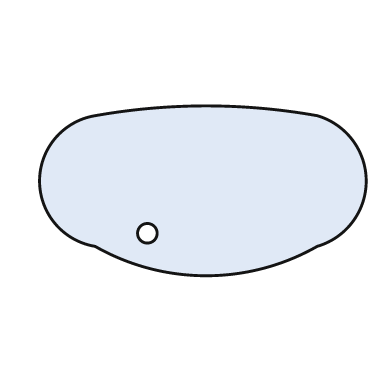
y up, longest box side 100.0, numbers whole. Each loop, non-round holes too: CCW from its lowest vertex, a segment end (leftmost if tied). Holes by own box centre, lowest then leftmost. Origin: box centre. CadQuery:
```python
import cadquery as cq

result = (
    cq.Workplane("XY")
    .moveTo(-33.0, -17.0)
    .threePointArc((1.0, -26.0), (35.0, -17.0))
    .threePointArc((50.0, 3.0), (35.0, 23.0))
    .threePointArc((1.0, 26.0), (-33.0, 23.0))
    .threePointArc((-50.0, 3.0), (-33.0, -17.0))
    .close()
    .moveTo(-17.0, -13.0)
    .circle(3.0)
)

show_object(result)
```